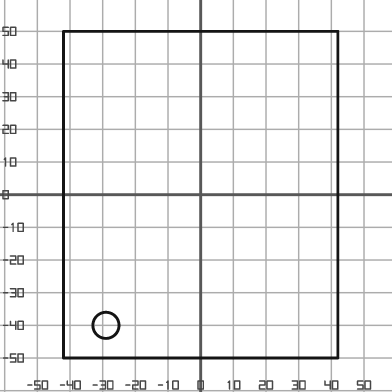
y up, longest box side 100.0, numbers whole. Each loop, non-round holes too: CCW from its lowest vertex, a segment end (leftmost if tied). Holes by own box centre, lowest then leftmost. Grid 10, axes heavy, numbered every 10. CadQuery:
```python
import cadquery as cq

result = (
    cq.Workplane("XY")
    .moveTo(-42.0, -50.0)
    .lineTo(42.0, -50.0)
    .lineTo(42.0, 50.0)
    .lineTo(-42.0, 50.0)
    .close()
    .moveTo(-29.0, -40.0)
    .circle(4.0)
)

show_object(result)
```